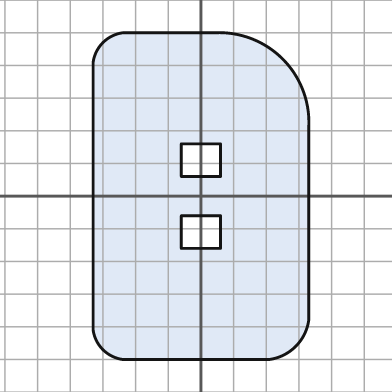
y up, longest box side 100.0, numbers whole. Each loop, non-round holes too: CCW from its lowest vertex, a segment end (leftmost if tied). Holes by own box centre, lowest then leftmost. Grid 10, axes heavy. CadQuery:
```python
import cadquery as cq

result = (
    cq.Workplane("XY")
    .moveTo(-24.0, -50.0)
    .lineTo(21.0, -50.0)
    .threePointArc((29.0, -46.0), (33.0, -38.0))
    .lineTo(33.0, 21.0)
    .threePointArc((25.0, 42.0), (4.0, 50.0))
    .lineTo(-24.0, 50.0)
    .threePointArc((-30.0, 47.0), (-33.0, 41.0))
    .lineTo(-33.0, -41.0)
    .threePointArc((-30.0, -47.0), (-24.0, -50.0))
    .close()
    .moveTo(-6.0, -16.0)
    .lineTo(6.0, -16.0)
    .lineTo(6.0, -6.0)
    .lineTo(-6.0, -6.0)
    .close()
    .moveTo(-6.0, 6.0)
    .lineTo(6.0, 6.0)
    .lineTo(6.0, 16.0)
    .lineTo(-6.0, 16.0)
    .close()
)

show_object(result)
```